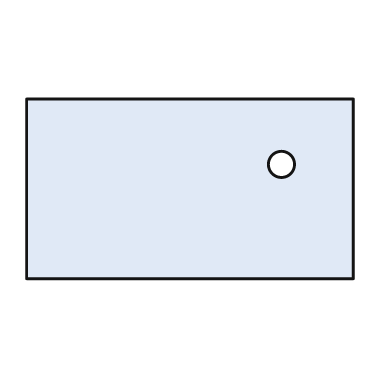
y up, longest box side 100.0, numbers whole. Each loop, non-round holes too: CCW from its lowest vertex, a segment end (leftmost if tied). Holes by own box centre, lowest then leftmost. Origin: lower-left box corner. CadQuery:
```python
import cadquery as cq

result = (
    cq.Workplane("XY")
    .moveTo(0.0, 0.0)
    .lineTo(100.0, 0.0)
    .lineTo(100.0, 55.0)
    .lineTo(0.0, 55.0)
    .close()
    .moveTo(78.0, 35.0)
    .circle(4.0)
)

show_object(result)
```